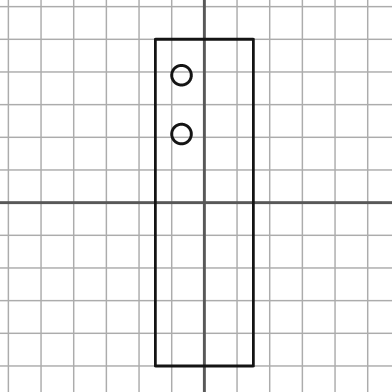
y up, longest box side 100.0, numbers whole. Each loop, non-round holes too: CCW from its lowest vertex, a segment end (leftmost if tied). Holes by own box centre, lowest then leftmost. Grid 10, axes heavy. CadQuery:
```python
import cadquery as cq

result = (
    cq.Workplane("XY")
    .moveTo(-15.0, -50.0)
    .lineTo(15.0, -50.0)
    .lineTo(15.0, 50.0)
    .lineTo(-15.0, 50.0)
    .close()
    .moveTo(-7.0, 21.0)
    .circle(3.0)
    .moveTo(-7.0, 39.0)
    .circle(3.0)
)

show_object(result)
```